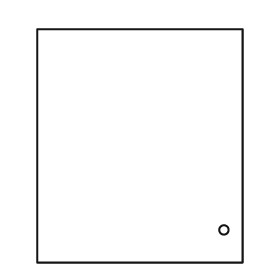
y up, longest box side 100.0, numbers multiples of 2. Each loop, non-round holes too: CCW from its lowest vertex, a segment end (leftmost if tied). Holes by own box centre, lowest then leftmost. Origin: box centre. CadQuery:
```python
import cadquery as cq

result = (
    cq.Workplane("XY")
    .moveTo(-44.0, -50.0)
    .lineTo(44.0, -50.0)
    .lineTo(44.0, 50.0)
    .lineTo(-44.0, 50.0)
    .close()
    .moveTo(36.0, -36.0)
    .circle(2.0)
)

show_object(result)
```